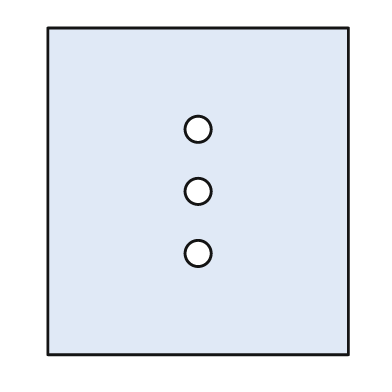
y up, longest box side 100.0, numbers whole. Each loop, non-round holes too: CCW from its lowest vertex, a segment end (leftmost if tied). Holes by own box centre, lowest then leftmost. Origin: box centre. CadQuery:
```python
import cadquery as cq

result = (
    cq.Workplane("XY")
    .moveTo(-46.0, -50.0)
    .lineTo(46.0, -50.0)
    .lineTo(46.0, 50.0)
    .lineTo(-46.0, 50.0)
    .close()
    .moveTo(0.0, -19.0)
    .circle(4.0)
    .moveTo(0.0, 0.0)
    .circle(4.0)
    .moveTo(0.0, 19.0)
    .circle(4.0)
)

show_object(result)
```